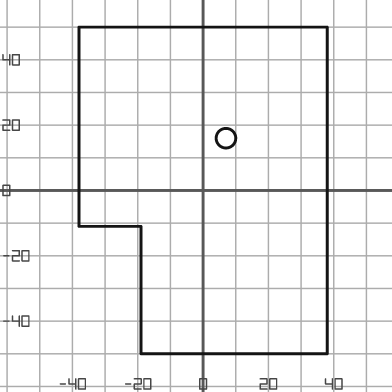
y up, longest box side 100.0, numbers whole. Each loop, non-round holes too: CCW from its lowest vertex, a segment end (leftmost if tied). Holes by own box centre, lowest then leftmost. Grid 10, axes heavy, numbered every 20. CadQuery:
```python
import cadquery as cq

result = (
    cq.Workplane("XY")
    .moveTo(-19.0, -50.0)
    .lineTo(38.0, -50.0)
    .lineTo(38.0, 50.0)
    .lineTo(-38.0, 50.0)
    .lineTo(-38.0, -11.0)
    .lineTo(-19.0, -11.0)
    .close()
    .moveTo(7.0, 16.0)
    .circle(3.0)
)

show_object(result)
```